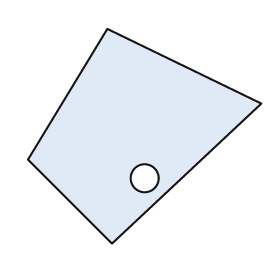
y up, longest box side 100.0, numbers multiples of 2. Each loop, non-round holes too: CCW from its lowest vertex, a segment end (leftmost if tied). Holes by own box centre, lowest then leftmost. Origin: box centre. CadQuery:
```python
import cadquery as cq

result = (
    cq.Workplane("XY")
    .moveTo(-14.0, -46.0)
    .lineTo(50.0, 14.0)
    .lineTo(-16.0, 46.0)
    .lineTo(-50.0, -10.0)
    .close()
    .moveTo(0.0, -18.0)
    .circle(6.0)
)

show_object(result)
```